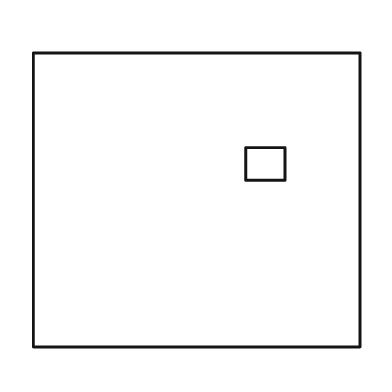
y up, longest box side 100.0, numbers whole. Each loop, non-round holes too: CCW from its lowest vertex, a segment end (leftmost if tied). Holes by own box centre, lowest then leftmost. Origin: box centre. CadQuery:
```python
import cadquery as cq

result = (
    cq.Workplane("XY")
    .moveTo(-50.0, -45.0)
    .lineTo(50.0, -45.0)
    .lineTo(50.0, 45.0)
    .lineTo(-50.0, 45.0)
    .close()
    .moveTo(15.0, 6.0)
    .lineTo(27.0, 6.0)
    .lineTo(27.0, 16.0)
    .lineTo(15.0, 16.0)
    .close()
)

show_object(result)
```